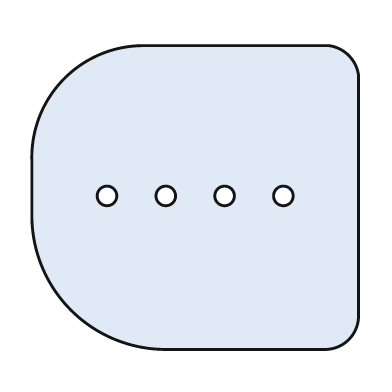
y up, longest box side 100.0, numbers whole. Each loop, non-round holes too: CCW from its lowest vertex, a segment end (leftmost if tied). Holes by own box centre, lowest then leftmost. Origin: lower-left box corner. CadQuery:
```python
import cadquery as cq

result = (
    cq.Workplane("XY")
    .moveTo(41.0, 0.0)
    .lineTo(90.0, 0.0)
    .threePointArc((97.0, 3.0), (100.0, 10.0))
    .lineTo(100.0, 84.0)
    .threePointArc((97.0, 90.0), (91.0, 93.0))
    .lineTo(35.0, 93.0)
    .threePointArc((10.0, 83.0), (0.0, 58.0))
    .lineTo(0.0, 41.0)
    .threePointArc((12.0, 12.0), (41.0, 0.0))
    .close()
    .moveTo(23.0, 47.0)
    .circle(3.0)
    .moveTo(41.0, 47.0)
    .circle(3.0)
    .moveTo(59.0, 47.0)
    .circle(3.0)
    .moveTo(77.0, 47.0)
    .circle(3.0)
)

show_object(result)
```